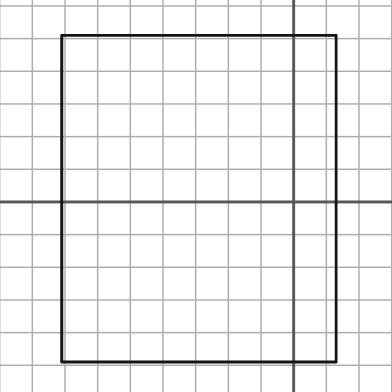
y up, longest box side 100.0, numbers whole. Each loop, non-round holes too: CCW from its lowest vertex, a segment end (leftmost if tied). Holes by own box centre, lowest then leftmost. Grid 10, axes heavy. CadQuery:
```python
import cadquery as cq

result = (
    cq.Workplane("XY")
    .moveTo(-71.0, -49.0)
    .lineTo(13.0, -49.0)
    .lineTo(13.0, 51.0)
    .lineTo(-71.0, 51.0)
    .close()
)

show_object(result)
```